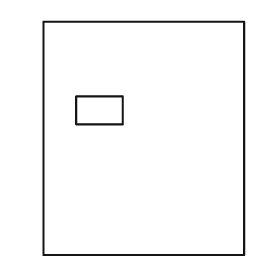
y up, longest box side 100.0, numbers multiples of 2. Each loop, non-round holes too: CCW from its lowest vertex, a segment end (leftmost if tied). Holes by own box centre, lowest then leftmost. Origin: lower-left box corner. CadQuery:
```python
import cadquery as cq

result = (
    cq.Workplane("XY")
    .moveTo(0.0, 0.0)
    .lineTo(86.0, 0.0)
    .lineTo(86.0, 100.0)
    .lineTo(0.0, 100.0)
    .close()
    .moveTo(14.0, 56.0)
    .lineTo(34.0, 56.0)
    .lineTo(34.0, 68.0)
    .lineTo(14.0, 68.0)
    .close()
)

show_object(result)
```